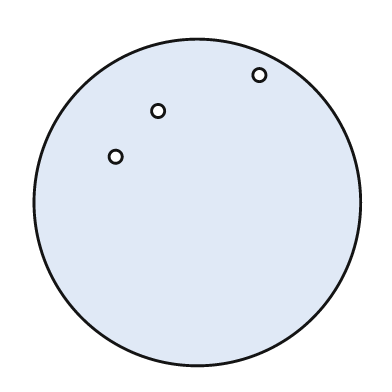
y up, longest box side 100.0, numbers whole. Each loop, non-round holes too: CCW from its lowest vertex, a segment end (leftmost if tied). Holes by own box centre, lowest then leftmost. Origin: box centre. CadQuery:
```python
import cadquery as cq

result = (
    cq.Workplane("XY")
    .moveTo(0.0, 0.0)
    .circle(50.0)
    .moveTo(-25.0, 14.0)
    .circle(2.0)
    .moveTo(-12.0, 28.0)
    .circle(2.0)
    .moveTo(19.0, 39.0)
    .circle(2.0)
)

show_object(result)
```